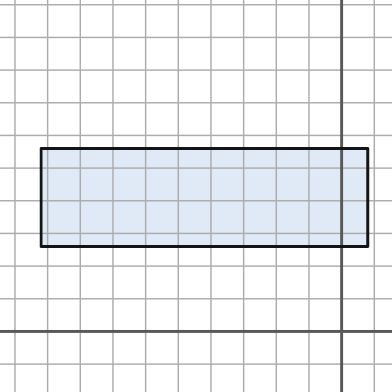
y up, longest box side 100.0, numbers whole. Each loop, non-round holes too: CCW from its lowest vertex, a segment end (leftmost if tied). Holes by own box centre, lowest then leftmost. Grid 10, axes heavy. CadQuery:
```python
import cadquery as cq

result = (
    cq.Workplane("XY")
    .moveTo(-92.0, 26.0)
    .lineTo(8.0, 26.0)
    .lineTo(8.0, 56.0)
    .lineTo(-92.0, 56.0)
    .close()
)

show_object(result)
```